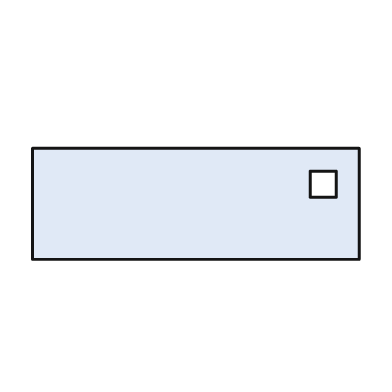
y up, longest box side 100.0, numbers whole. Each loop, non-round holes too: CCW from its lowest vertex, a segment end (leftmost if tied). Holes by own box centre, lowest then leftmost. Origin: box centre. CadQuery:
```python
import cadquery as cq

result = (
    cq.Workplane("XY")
    .moveTo(-50.0, -17.0)
    .lineTo(50.0, -17.0)
    .lineTo(50.0, 17.0)
    .lineTo(-50.0, 17.0)
    .close()
    .moveTo(35.0, 2.0)
    .lineTo(43.0, 2.0)
    .lineTo(43.0, 10.0)
    .lineTo(35.0, 10.0)
    .close()
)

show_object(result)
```